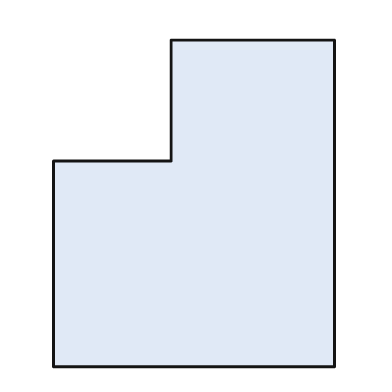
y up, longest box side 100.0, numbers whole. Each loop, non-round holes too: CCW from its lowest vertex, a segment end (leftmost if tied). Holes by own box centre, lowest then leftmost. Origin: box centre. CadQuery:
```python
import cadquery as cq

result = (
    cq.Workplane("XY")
    .moveTo(-43.0, -50.0)
    .lineTo(43.0, -50.0)
    .lineTo(43.0, 50.0)
    .lineTo(-7.0, 50.0)
    .lineTo(-7.0, 13.0)
    .lineTo(-43.0, 13.0)
    .close()
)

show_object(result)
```